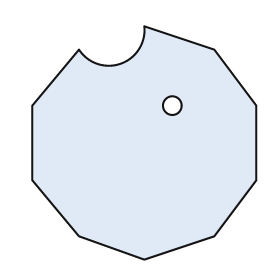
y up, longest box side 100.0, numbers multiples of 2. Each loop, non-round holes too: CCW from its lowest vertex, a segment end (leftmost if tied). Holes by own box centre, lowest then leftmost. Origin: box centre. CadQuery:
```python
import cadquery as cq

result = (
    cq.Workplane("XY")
    .moveTo(0.0, -50.0)
    .lineTo(30.0, -40.0)
    .lineTo(48.0, -16.0)
    .lineTo(48.0, 16.0)
    .lineTo(30.0, 40.0)
    .lineTo(0.0, 50.0)
    .threePointArc((-10.0, 34.0), (-28.0, 40.0))
    .lineTo(-48.0, 16.0)
    .lineTo(-48.0, -16.0)
    .lineTo(-28.0, -40.0)
    .close()
    .moveTo(12.0, 16.0)
    .circle(4.0)
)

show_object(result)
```